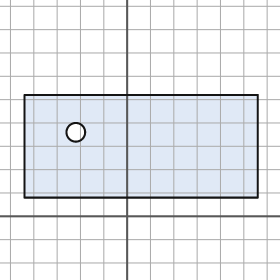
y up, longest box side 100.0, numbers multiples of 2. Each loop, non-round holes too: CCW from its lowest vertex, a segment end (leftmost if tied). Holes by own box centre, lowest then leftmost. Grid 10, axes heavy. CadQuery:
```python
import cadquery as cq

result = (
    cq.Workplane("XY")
    .moveTo(-44.0, 8.0)
    .lineTo(56.0, 8.0)
    .lineTo(56.0, 52.0)
    .lineTo(-44.0, 52.0)
    .close()
    .moveTo(-22.0, 36.0)
    .circle(4.0)
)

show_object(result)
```